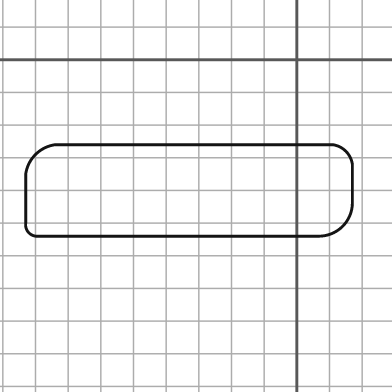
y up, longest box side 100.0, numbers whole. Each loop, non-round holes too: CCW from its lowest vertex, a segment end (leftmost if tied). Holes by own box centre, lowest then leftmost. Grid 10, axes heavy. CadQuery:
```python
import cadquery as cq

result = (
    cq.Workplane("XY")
    .moveTo(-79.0, -54.0)
    .lineTo(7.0, -54.0)
    .threePointArc((14.0, -51.0), (17.0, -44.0))
    .lineTo(17.0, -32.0)
    .threePointArc((15.0, -28.0), (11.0, -26.0))
    .lineTo(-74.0, -26.0)
    .threePointArc((-80.0, -29.0), (-83.0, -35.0))
    .lineTo(-83.0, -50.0)
    .threePointArc((-82.0, -53.0), (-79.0, -54.0))
    .close()
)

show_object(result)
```